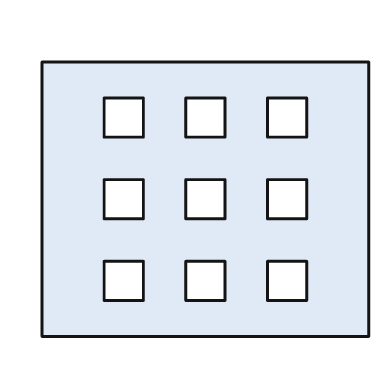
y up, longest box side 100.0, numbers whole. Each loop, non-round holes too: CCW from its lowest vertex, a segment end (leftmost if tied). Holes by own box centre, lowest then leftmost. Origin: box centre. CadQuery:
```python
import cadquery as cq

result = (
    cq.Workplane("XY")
    .moveTo(-50.0, -42.0)
    .lineTo(50.0, -42.0)
    .lineTo(50.0, 42.0)
    .lineTo(-50.0, 42.0)
    .close()
    .moveTo(-31.0, -31.0)
    .lineTo(-19.0, -31.0)
    .lineTo(-19.0, -19.0)
    .lineTo(-31.0, -19.0)
    .close()
    .moveTo(-6.0, -31.0)
    .lineTo(6.0, -31.0)
    .lineTo(6.0, -19.0)
    .lineTo(-6.0, -19.0)
    .close()
    .moveTo(19.0, -31.0)
    .lineTo(31.0, -31.0)
    .lineTo(31.0, -19.0)
    .lineTo(19.0, -19.0)
    .close()
    .moveTo(-31.0, -6.0)
    .lineTo(-19.0, -6.0)
    .lineTo(-19.0, 6.0)
    .lineTo(-31.0, 6.0)
    .close()
    .moveTo(-6.0, -6.0)
    .lineTo(6.0, -6.0)
    .lineTo(6.0, 6.0)
    .lineTo(-6.0, 6.0)
    .close()
    .moveTo(19.0, -6.0)
    .lineTo(31.0, -6.0)
    .lineTo(31.0, 6.0)
    .lineTo(19.0, 6.0)
    .close()
    .moveTo(-31.0, 19.0)
    .lineTo(-19.0, 19.0)
    .lineTo(-19.0, 31.0)
    .lineTo(-31.0, 31.0)
    .close()
    .moveTo(-6.0, 19.0)
    .lineTo(6.0, 19.0)
    .lineTo(6.0, 31.0)
    .lineTo(-6.0, 31.0)
    .close()
    .moveTo(19.0, 19.0)
    .lineTo(31.0, 19.0)
    .lineTo(31.0, 31.0)
    .lineTo(19.0, 31.0)
    .close()
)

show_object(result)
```